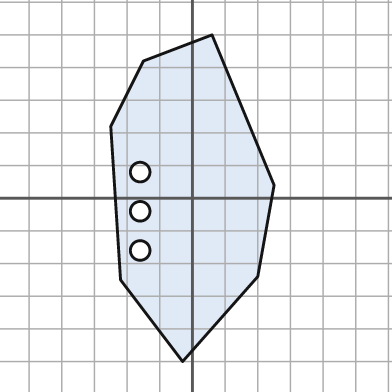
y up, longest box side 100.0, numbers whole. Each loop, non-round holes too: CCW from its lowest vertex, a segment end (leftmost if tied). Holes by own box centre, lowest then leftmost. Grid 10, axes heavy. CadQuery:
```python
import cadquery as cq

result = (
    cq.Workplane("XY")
    .moveTo(-3.0, -50.0)
    .lineTo(20.0, -24.0)
    .lineTo(25.0, 4.0)
    .lineTo(6.0, 50.0)
    .lineTo(-15.0, 42.0)
    .lineTo(-25.0, 22.0)
    .lineTo(-22.0, -25.0)
    .close()
    .moveTo(-16.0, -16.0)
    .circle(3.0)
    .moveTo(-16.0, -4.0)
    .circle(3.0)
    .moveTo(-16.0, 8.0)
    .circle(3.0)
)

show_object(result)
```